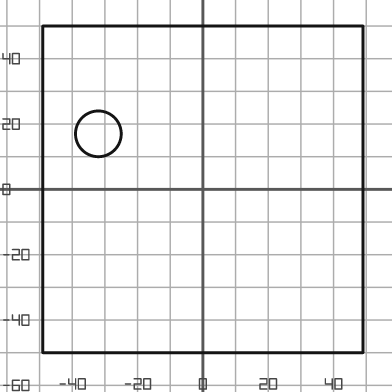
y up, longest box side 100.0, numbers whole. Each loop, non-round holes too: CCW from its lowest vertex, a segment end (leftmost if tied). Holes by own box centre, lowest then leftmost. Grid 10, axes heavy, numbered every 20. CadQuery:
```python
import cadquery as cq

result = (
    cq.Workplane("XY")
    .moveTo(-49.0, -50.0)
    .lineTo(49.0, -50.0)
    .lineTo(49.0, 50.0)
    .lineTo(-49.0, 50.0)
    .close()
    .moveTo(-32.0, 17.0)
    .circle(7.0)
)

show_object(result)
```